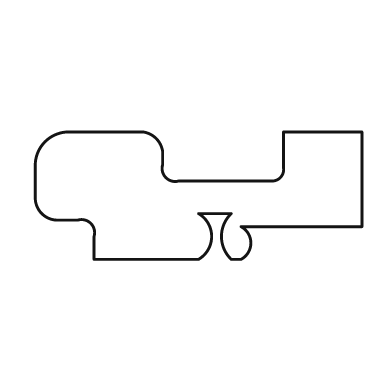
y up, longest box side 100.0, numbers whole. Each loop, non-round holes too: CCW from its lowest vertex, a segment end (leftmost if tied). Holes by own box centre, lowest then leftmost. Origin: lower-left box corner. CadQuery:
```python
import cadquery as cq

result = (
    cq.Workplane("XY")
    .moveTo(18.0, 0.0)
    .lineTo(50.0, 0.0)
    .threePointArc((54.0, 7.0), (50.0, 14.0))
    .lineTo(60.0, 14.0)
    .threePointArc((57.0, 7.0), (60.0, 0.0))
    .lineTo(63.0, 0.0)
    .threePointArc((66.0, 5.0), (63.0, 10.0))
    .lineTo(100.0, 10.0)
    .lineTo(100.0, 39.0)
    .lineTo(76.0, 39.0)
    .lineTo(76.0, 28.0)
    .threePointArc((75.0, 25.0), (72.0, 24.0))
    .lineTo(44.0, 24.0)
    .threePointArc((40.0, 25.0), (39.0, 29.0))
    .lineTo(39.0, 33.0)
    .threePointArc((37.0, 37.0), (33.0, 39.0))
    .lineTo(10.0, 39.0)
    .threePointArc((3.0, 36.0), (0.0, 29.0))
    .lineTo(0.0, 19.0)
    .threePointArc((2.0, 14.0), (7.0, 12.0))
    .lineTo(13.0, 12.0)
    .threePointArc((17.0, 11.0), (18.0, 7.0))
    .close()
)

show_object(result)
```